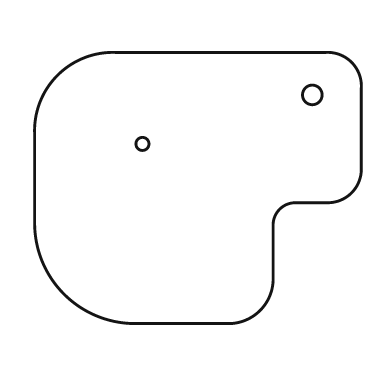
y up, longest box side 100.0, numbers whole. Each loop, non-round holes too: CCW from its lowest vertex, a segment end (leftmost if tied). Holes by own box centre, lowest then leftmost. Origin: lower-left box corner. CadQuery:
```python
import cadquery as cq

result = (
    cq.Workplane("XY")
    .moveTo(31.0, 0.0)
    .lineTo(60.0, 0.0)
    .threePointArc((69.0, 4.0), (73.0, 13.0))
    .lineTo(73.0, 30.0)
    .threePointArc((75.0, 35.0), (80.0, 37.0))
    .lineTo(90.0, 37.0)
    .threePointArc((97.0, 40.0), (100.0, 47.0))
    .lineTo(100.0, 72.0)
    .threePointArc((97.0, 80.0), (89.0, 83.0))
    .lineTo(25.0, 83.0)
    .threePointArc((7.0, 76.0), (0.0, 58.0))
    .lineTo(0.0, 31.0)
    .threePointArc((9.0, 9.0), (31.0, 0.0))
    .close()
    .moveTo(33.0, 55.0)
    .circle(2.0)
    .moveTo(85.0, 70.0)
    .circle(3.0)
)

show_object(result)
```